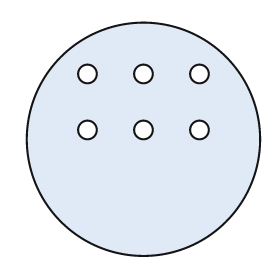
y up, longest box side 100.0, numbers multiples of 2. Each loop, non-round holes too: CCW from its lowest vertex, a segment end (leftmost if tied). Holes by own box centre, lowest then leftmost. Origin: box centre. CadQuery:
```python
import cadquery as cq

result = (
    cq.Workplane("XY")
    .moveTo(0.0, 0.0)
    .circle(50.0)
    .moveTo(-24.0, 4.0)
    .circle(4.0)
    .moveTo(0.0, 4.0)
    .circle(4.0)
    .moveTo(24.0, 4.0)
    .circle(4.0)
    .moveTo(-24.0, 28.0)
    .circle(4.0)
    .moveTo(0.0, 28.0)
    .circle(4.0)
    .moveTo(24.0, 28.0)
    .circle(4.0)
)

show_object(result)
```